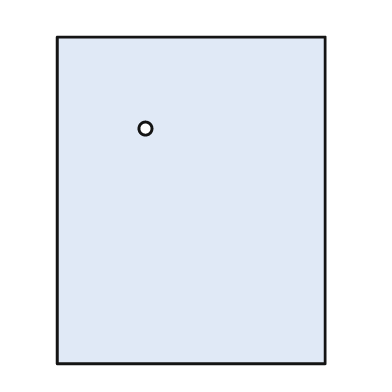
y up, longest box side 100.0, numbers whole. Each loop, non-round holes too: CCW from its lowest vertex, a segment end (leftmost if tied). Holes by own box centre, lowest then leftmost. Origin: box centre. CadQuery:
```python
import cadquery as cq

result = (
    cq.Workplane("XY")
    .moveTo(-41.0, -50.0)
    .lineTo(41.0, -50.0)
    .lineTo(41.0, 50.0)
    .lineTo(-41.0, 50.0)
    .close()
    .moveTo(-14.0, 22.0)
    .circle(2.0)
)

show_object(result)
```